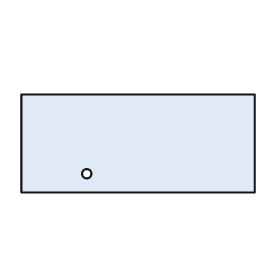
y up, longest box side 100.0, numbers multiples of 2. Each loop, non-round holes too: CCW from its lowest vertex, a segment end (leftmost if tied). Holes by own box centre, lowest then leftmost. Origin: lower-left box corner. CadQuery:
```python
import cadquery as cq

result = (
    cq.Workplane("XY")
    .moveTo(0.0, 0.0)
    .lineTo(100.0, 0.0)
    .lineTo(100.0, 42.0)
    .lineTo(0.0, 42.0)
    .close()
    .moveTo(28.0, 8.0)
    .circle(2.0)
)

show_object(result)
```